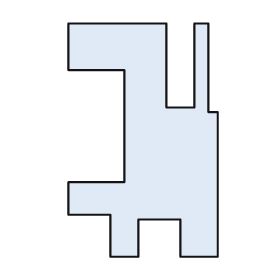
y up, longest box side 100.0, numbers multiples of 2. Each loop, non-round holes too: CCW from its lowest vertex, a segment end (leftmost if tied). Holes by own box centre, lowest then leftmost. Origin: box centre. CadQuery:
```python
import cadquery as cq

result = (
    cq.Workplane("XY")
    .moveTo(-14.0, -50.0)
    .lineTo(-2.0, -50.0)
    .lineTo(-2.0, -34.0)
    .lineTo(16.0, -34.0)
    .lineTo(16.0, -50.0)
    .lineTo(32.0, -50.0)
    .lineTo(32.0, 12.0)
    .lineTo(28.0, 12.0)
    .lineTo(28.0, 50.0)
    .lineTo(22.0, 50.0)
    .lineTo(22.0, 14.0)
    .lineTo(10.0, 14.0)
    .lineTo(10.0, 50.0)
    .lineTo(-32.0, 50.0)
    .lineTo(-32.0, 30.0)
    .lineTo(-8.0, 30.0)
    .lineTo(-8.0, -18.0)
    .lineTo(-32.0, -18.0)
    .lineTo(-32.0, -32.0)
    .lineTo(-14.0, -32.0)
    .close()
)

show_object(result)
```